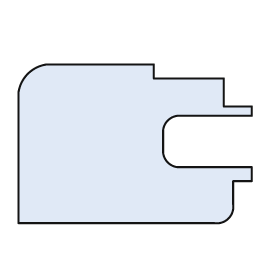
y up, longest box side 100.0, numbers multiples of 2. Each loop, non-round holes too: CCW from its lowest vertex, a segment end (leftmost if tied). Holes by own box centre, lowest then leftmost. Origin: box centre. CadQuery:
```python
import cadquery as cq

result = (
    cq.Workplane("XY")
    .moveTo(-50.0, -34.0)
    .lineTo(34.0, -34.0)
    .threePointArc((40.0, -32.0), (42.0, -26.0))
    .lineTo(42.0, -16.0)
    .lineTo(50.0, -16.0)
    .lineTo(50.0, -10.0)
    .lineTo(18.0, -10.0)
    .threePointArc((14.0, -8.0), (12.0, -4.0))
    .lineTo(12.0, 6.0)
    .threePointArc((14.0, 10.0), (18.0, 12.0))
    .lineTo(50.0, 12.0)
    .lineTo(50.0, 16.0)
    .lineTo(38.0, 16.0)
    .lineTo(38.0, 28.0)
    .lineTo(8.0, 28.0)
    .lineTo(8.0, 34.0)
    .lineTo(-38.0, 34.0)
    .threePointArc((-46.0, 30.0), (-50.0, 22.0))
    .close()
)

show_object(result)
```